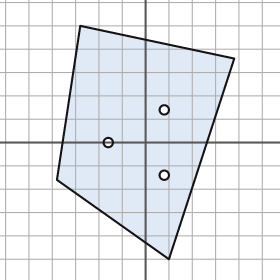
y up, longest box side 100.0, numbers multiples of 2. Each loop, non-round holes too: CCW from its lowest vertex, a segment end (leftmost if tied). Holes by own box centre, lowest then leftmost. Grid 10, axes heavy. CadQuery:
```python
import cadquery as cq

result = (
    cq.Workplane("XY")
    .moveTo(10.0, -50.0)
    .lineTo(38.0, 36.0)
    .lineTo(-28.0, 50.0)
    .lineTo(-38.0, -16.0)
    .close()
    .moveTo(8.0, -14.0)
    .circle(2.0)
    .moveTo(-16.0, 0.0)
    .circle(2.0)
    .moveTo(8.0, 14.0)
    .circle(2.0)
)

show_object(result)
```